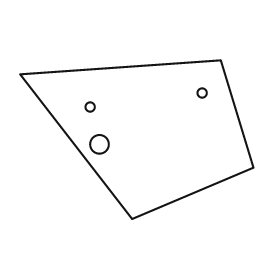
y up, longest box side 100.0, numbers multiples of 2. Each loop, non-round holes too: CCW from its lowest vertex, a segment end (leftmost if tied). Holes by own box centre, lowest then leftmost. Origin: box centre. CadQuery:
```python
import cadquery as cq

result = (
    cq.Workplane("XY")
    .moveTo(-2.0, -34.0)
    .lineTo(50.0, -12.0)
    .lineTo(36.0, 34.0)
    .lineTo(-50.0, 28.0)
    .close()
    .moveTo(-16.0, -2.0)
    .circle(4.0)
    .moveTo(-20.0, 14.0)
    .circle(2.0)
    .moveTo(28.0, 20.0)
    .circle(2.0)
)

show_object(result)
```